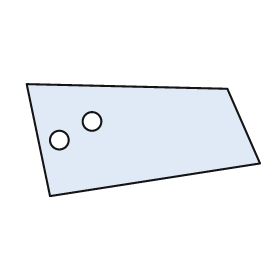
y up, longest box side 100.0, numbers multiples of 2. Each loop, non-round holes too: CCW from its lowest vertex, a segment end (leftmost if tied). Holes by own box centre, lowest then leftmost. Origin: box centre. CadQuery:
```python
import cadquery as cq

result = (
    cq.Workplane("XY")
    .moveTo(-40.0, -24.0)
    .lineTo(50.0, -10.0)
    .lineTo(36.0, 22.0)
    .lineTo(-50.0, 24.0)
    .close()
    .moveTo(-36.0, 0.0)
    .circle(4.0)
    .moveTo(-22.0, 8.0)
    .circle(4.0)
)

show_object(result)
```